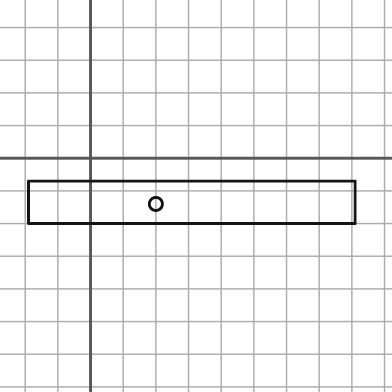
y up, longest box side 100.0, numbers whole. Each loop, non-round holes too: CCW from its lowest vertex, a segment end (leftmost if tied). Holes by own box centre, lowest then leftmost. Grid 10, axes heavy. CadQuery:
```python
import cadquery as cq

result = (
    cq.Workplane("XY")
    .moveTo(-19.0, -20.0)
    .lineTo(81.0, -20.0)
    .lineTo(81.0, -7.0)
    .lineTo(-19.0, -7.0)
    .close()
    .moveTo(20.0, -14.0)
    .circle(2.0)
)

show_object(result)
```